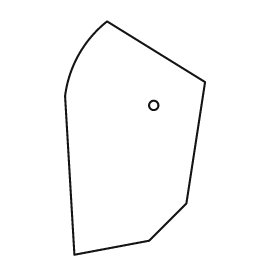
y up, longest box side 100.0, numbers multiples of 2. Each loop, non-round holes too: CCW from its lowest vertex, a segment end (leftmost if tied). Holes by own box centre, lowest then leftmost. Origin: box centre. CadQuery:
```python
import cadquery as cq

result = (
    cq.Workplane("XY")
    .moveTo(-26.0, -50.0)
    .lineTo(6.0, -44.0)
    .lineTo(22.0, -28.0)
    .lineTo(30.0, 24.0)
    .lineTo(-12.0, 50.0)
    .threePointArc((-24.0, 36.0), (-30.0, 18.0))
    .close()
    .moveTo(8.0, 14.0)
    .circle(2.0)
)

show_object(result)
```